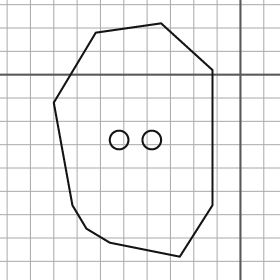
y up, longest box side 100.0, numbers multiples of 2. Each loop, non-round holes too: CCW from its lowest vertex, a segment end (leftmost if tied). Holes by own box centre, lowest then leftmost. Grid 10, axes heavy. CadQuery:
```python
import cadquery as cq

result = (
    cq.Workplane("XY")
    .moveTo(-26.0, -78.0)
    .lineTo(-12.0, -56.0)
    .lineTo(-12.0, 2.0)
    .lineTo(-34.0, 22.0)
    .lineTo(-62.0, 18.0)
    .lineTo(-80.0, -12.0)
    .lineTo(-72.0, -56.0)
    .lineTo(-66.0, -66.0)
    .lineTo(-56.0, -72.0)
    .close()
    .moveTo(-52.0, -28.0)
    .circle(4.0)
    .moveTo(-38.0, -28.0)
    .circle(4.0)
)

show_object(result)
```